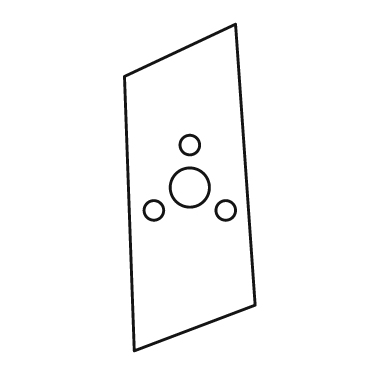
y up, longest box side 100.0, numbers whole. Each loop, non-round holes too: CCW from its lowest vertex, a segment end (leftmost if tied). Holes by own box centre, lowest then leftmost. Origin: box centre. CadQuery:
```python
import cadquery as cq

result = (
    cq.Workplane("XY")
    .moveTo(-17.0, -50.0)
    .lineTo(20.0, -36.0)
    .lineTo(14.0, 50.0)
    .lineTo(-20.0, 34.0)
    .close()
    .moveTo(-11.0, -7.0)
    .circle(3.0)
    .moveTo(11.0, -7.0)
    .circle(3.0)
    .moveTo(0.0, 0.0)
    .circle(6.0)
    .moveTo(0.0, 13.0)
    .circle(3.0)
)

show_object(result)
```